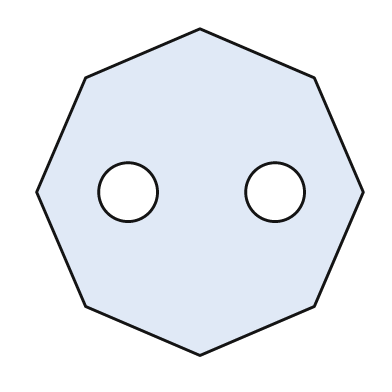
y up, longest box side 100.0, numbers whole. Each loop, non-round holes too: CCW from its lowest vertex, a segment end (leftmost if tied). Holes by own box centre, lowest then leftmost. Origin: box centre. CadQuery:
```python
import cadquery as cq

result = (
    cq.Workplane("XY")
    .moveTo(0.0, -50.0)
    .lineTo(35.0, -35.0)
    .lineTo(50.0, 0.0)
    .lineTo(35.0, 35.0)
    .lineTo(0.0, 50.0)
    .lineTo(-35.0, 35.0)
    .lineTo(-50.0, 0.0)
    .lineTo(-35.0, -35.0)
    .close()
    .moveTo(-22.0, 0.0)
    .circle(9.0)
    .moveTo(23.0, 0.0)
    .circle(9.0)
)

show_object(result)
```